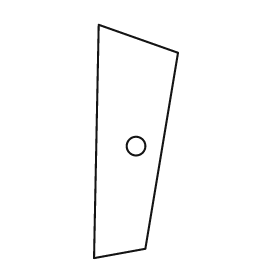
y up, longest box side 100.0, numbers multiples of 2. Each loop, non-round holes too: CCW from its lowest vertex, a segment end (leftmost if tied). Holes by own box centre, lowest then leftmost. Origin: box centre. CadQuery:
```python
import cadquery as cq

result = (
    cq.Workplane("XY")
    .moveTo(-18.0, -50.0)
    .lineTo(4.0, -46.0)
    .lineTo(18.0, 38.0)
    .lineTo(-16.0, 50.0)
    .close()
    .moveTo(0.0, -2.0)
    .circle(4.0)
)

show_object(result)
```